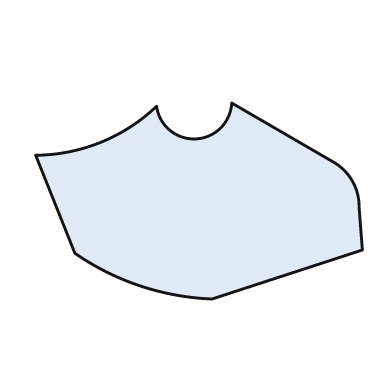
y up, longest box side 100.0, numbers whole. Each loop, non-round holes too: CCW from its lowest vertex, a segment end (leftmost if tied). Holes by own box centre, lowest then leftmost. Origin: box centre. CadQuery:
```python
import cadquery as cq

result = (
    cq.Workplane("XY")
    .moveTo(4.0, -30.0)
    .lineTo(50.0, -15.0)
    .lineTo(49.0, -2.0)
    .threePointArc((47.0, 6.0), (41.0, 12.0))
    .lineTo(10.0, 30.0)
    .threePointArc((-1.0, 19.0), (-13.0, 29.0))
    .threePointArc((-30.0, 18.0), (-50.0, 14.0))
    .lineTo(-38.0, -16.0)
    .threePointArc((-18.0, -26.0), (4.0, -30.0))
    .close()
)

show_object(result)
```